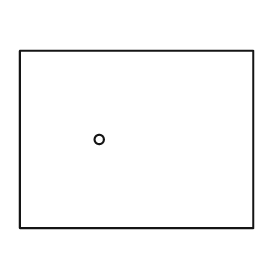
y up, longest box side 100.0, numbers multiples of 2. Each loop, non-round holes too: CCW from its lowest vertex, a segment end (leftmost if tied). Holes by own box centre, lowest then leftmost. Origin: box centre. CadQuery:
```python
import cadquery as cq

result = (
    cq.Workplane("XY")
    .moveTo(-50.0, -38.0)
    .lineTo(50.0, -38.0)
    .lineTo(50.0, 38.0)
    .lineTo(-50.0, 38.0)
    .close()
    .moveTo(-16.0, 0.0)
    .circle(2.0)
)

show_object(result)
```